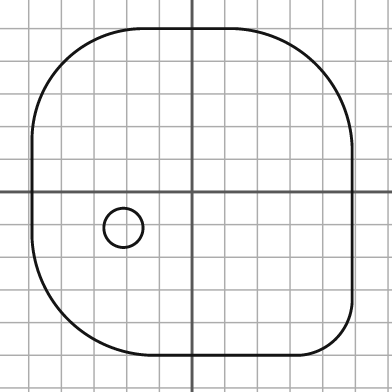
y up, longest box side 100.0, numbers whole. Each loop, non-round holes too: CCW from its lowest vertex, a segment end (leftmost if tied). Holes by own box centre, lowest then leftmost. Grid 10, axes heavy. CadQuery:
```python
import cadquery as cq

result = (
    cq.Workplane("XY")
    .moveTo(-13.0, -50.0)
    .lineTo(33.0, -50.0)
    .threePointArc((44.0, -45.0), (49.0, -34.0))
    .lineTo(49.0, 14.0)
    .threePointArc((38.0, 39.0), (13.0, 50.0))
    .lineTo(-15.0, 50.0)
    .threePointArc((-39.0, 40.0), (-49.0, 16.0))
    .lineTo(-49.0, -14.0)
    .threePointArc((-38.0, -39.0), (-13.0, -50.0))
    .close()
    .moveTo(-21.0, -11.0)
    .circle(6.0)
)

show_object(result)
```